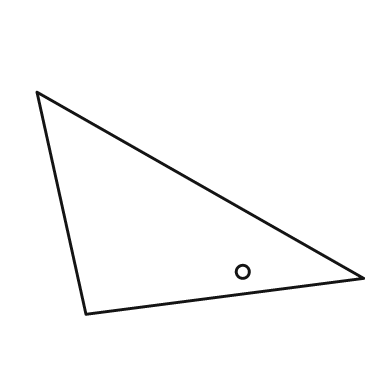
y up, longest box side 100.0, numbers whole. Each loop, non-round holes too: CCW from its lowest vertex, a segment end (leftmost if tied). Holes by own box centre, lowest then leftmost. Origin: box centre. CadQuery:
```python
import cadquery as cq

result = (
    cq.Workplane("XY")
    .moveTo(-35.0, -34.0)
    .lineTo(50.0, -23.0)
    .lineTo(-50.0, 34.0)
    .close()
    .moveTo(13.0, -21.0)
    .circle(2.0)
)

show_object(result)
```